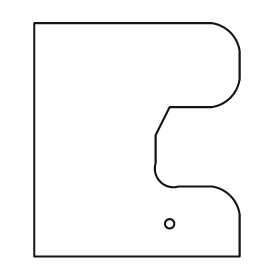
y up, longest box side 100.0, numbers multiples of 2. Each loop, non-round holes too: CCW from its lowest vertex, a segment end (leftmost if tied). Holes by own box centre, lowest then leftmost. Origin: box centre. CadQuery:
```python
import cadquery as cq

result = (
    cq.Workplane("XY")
    .moveTo(-44.0, -50.0)
    .lineTo(44.0, -50.0)
    .lineTo(44.0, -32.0)
    .threePointArc((40.0, -24.0), (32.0, -20.0))
    .lineTo(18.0, -20.0)
    .threePointArc((10.0, -18.0), (8.0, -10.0))
    .lineTo(8.0, 2.0)
    .lineTo(14.0, 14.0)
    .lineTo(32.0, 14.0)
    .threePointArc((40.0, 18.0), (44.0, 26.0))
    .lineTo(44.0, 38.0)
    .threePointArc((40.0, 46.0), (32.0, 50.0))
    .lineTo(-44.0, 50.0)
    .close()
    .moveTo(14.0, -36.0)
    .circle(2.0)
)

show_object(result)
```